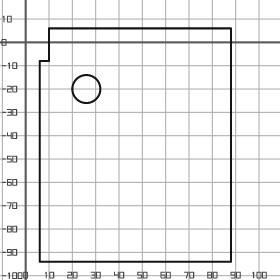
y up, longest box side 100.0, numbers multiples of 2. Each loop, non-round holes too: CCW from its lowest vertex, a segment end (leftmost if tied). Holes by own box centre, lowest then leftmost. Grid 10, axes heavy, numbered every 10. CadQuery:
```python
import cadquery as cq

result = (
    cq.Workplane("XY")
    .moveTo(6.0, -94.0)
    .lineTo(88.0, -94.0)
    .lineTo(88.0, 6.0)
    .lineTo(10.0, 6.0)
    .lineTo(10.0, -8.0)
    .lineTo(6.0, -8.0)
    .close()
    .moveTo(26.0, -20.0)
    .circle(6.0)
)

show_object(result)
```